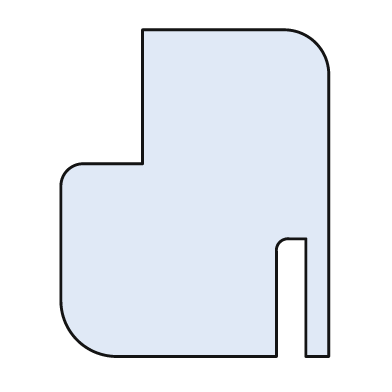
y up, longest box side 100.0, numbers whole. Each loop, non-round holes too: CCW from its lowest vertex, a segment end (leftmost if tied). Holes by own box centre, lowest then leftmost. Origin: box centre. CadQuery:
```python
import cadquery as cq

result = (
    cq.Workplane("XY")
    .moveTo(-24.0, -50.0)
    .lineTo(25.0, -50.0)
    .lineTo(25.0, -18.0)
    .threePointArc((26.0, -15.0), (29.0, -14.0))
    .lineTo(34.0, -14.0)
    .lineTo(34.0, -50.0)
    .lineTo(41.0, -50.0)
    .lineTo(41.0, 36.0)
    .threePointArc((37.0, 46.0), (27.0, 50.0))
    .lineTo(-16.0, 50.0)
    .lineTo(-16.0, 9.0)
    .lineTo(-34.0, 9.0)
    .threePointArc((-39.0, 7.0), (-41.0, 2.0))
    .lineTo(-41.0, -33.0)
    .threePointArc((-36.0, -45.0), (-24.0, -50.0))
    .close()
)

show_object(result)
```